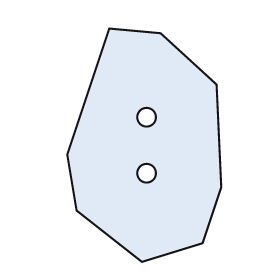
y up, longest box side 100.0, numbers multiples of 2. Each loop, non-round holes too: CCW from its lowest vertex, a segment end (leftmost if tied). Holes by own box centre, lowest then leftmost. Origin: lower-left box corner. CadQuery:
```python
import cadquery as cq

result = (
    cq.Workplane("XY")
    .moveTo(32.0, 0.0)
    .lineTo(58.0, 8.0)
    .lineTo(66.0, 32.0)
    .lineTo(64.0, 76.0)
    .lineTo(40.0, 98.0)
    .lineTo(18.0, 100.0)
    .lineTo(0.0, 46.0)
    .lineTo(4.0, 22.0)
    .close()
    .moveTo(34.0, 38.0)
    .circle(4.0)
    .moveTo(34.0, 62.0)
    .circle(4.0)
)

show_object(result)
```